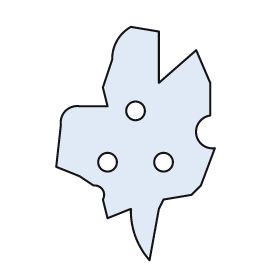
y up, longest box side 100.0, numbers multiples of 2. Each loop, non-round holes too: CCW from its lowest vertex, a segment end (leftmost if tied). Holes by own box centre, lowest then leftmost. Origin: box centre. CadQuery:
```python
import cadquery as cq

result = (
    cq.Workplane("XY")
    .moveTo(6.0, -50.0)
    .lineTo(10.0, -28.0)
    .lineTo(12.0, -24.0)
    .lineTo(24.0, -22.0)
    .lineTo(28.0, -18.0)
    .lineTo(34.0, -2.0)
    .threePointArc((26.0, 4.0), (32.0, 12.0))
    .lineTo(32.0, 26.0)
    .lineTo(26.0, 40.0)
    .lineTo(10.0, 26.0)
    .lineTo(10.0, 48.0)
    .lineTo(-2.0, 50.0)
    .threePointArc((-8.0, 44.0), (-10.0, 36.0))
    .lineTo(-14.0, 24.0)
    .lineTo(-12.0, 16.0)
    .lineTo(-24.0, 16.0)
    .threePointArc((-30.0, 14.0), (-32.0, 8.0))
    .lineTo(-34.0, -10.0)
    .lineTo(-24.0, -14.0)
    .lineTo(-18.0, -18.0)
    .threePointArc((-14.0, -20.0), (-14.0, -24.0))
    .lineTo(-12.0, -32.0)
    .lineTo(-2.0, -28.0)
    .threePointArc((0.0, -40.0), (6.0, -50.0))
    .close()
    .moveTo(-12.0, -8.0)
    .circle(4.0)
    .moveTo(12.0, -8.0)
    .circle(4.0)
    .moveTo(0.0, 14.0)
    .circle(4.0)
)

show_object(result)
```